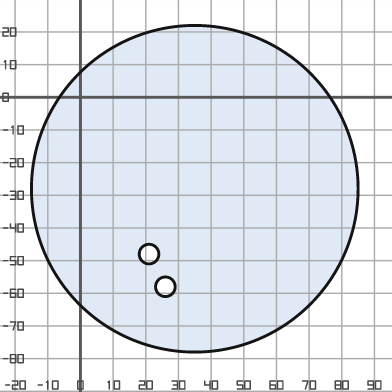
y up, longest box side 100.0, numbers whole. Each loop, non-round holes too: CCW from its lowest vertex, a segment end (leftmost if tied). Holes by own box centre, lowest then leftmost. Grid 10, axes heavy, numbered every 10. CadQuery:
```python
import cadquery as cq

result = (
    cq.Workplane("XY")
    .moveTo(35.0, -28.0)
    .circle(50.0)
    .moveTo(26.0, -58.0)
    .circle(3.0)
    .moveTo(21.0, -48.0)
    .circle(3.0)
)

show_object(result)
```